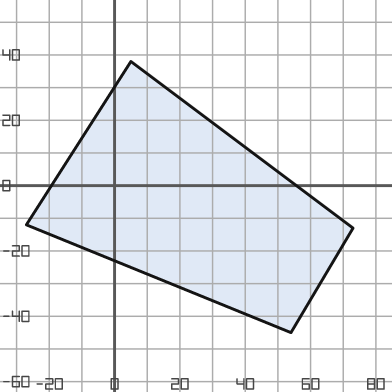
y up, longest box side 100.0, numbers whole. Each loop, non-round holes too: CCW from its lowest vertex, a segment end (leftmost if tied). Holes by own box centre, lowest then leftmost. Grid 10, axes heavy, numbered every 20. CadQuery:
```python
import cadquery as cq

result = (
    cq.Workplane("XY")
    .moveTo(54.0, -45.0)
    .lineTo(73.0, -13.0)
    .lineTo(5.0, 38.0)
    .lineTo(-27.0, -12.0)
    .close()
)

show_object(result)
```